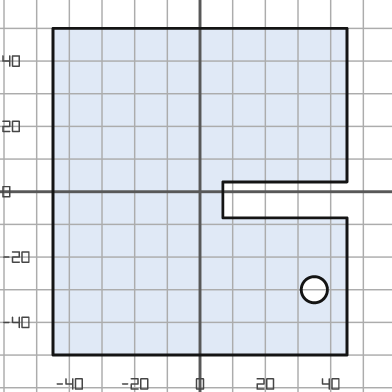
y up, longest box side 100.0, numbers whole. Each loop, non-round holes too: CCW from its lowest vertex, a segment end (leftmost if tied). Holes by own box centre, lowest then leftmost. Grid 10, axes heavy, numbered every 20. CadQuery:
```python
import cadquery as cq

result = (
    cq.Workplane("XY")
    .moveTo(-45.0, -50.0)
    .lineTo(45.0, -50.0)
    .lineTo(45.0, -8.0)
    .lineTo(7.0, -8.0)
    .lineTo(7.0, 3.0)
    .lineTo(45.0, 3.0)
    .lineTo(45.0, 50.0)
    .lineTo(-45.0, 50.0)
    .close()
    .moveTo(35.0, -30.0)
    .circle(4.0)
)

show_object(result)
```